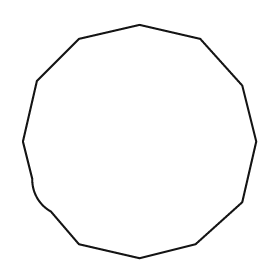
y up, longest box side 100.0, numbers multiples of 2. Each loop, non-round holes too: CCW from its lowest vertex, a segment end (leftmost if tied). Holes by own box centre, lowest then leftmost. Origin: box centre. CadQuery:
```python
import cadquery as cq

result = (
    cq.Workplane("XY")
    .moveTo(0.0, -50.0)
    .lineTo(24.0, -44.0)
    .lineTo(44.0, -26.0)
    .lineTo(50.0, 0.0)
    .lineTo(44.0, 24.0)
    .lineTo(26.0, 44.0)
    .lineTo(0.0, 50.0)
    .lineTo(-26.0, 44.0)
    .lineTo(-44.0, 26.0)
    .lineTo(-50.0, 0.0)
    .lineTo(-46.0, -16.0)
    .threePointArc((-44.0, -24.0), (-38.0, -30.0))
    .lineTo(-26.0, -44.0)
    .close()
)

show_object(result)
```